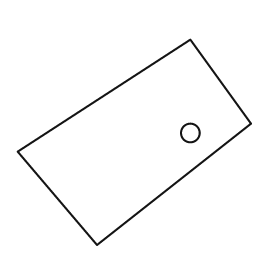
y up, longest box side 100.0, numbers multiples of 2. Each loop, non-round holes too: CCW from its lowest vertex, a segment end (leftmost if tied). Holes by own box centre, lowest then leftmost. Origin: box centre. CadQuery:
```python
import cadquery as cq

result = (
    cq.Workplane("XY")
    .moveTo(-16.0, -44.0)
    .lineTo(50.0, 8.0)
    .lineTo(24.0, 44.0)
    .lineTo(-50.0, -4.0)
    .close()
    .moveTo(24.0, 4.0)
    .circle(4.0)
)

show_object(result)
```